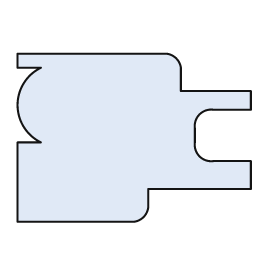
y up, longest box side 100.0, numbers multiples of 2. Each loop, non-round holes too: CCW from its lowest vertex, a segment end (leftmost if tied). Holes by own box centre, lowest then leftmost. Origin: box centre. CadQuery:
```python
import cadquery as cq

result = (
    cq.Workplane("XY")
    .moveTo(-50.0, -36.0)
    .lineTo(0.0, -36.0)
    .threePointArc((4.0, -34.0), (6.0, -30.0))
    .lineTo(6.0, -22.0)
    .lineTo(50.0, -22.0)
    .lineTo(50.0, -10.0)
    .lineTo(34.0, -10.0)
    .threePointArc((28.0, -8.0), (26.0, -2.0))
    .lineTo(26.0, 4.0)
    .threePointArc((28.0, 10.0), (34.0, 12.0))
    .lineTo(50.0, 12.0)
    .lineTo(50.0, 20.0)
    .lineTo(20.0, 20.0)
    .lineTo(20.0, 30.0)
    .threePointArc((18.0, 34.0), (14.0, 36.0))
    .lineTo(-50.0, 36.0)
    .lineTo(-50.0, 30.0)
    .lineTo(-40.0, 30.0)
    .threePointArc((-50.0, 14.0), (-40.0, -2.0))
    .lineTo(-50.0, -2.0)
    .close()
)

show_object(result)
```